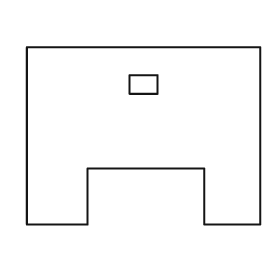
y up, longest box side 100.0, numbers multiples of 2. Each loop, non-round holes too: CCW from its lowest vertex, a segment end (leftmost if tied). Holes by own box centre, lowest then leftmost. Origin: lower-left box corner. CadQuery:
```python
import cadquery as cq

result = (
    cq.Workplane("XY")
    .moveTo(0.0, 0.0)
    .lineTo(26.0, 0.0)
    .lineTo(26.0, 24.0)
    .lineTo(76.0, 24.0)
    .lineTo(76.0, 0.0)
    .lineTo(100.0, 0.0)
    .lineTo(100.0, 76.0)
    .lineTo(0.0, 76.0)
    .close()
    .moveTo(44.0, 56.0)
    .lineTo(56.0, 56.0)
    .lineTo(56.0, 64.0)
    .lineTo(44.0, 64.0)
    .close()
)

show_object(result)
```